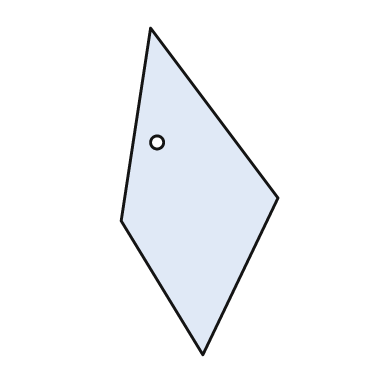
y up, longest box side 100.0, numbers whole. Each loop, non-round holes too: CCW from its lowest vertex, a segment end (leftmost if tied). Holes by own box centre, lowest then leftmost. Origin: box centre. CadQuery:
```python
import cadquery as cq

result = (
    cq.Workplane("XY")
    .moveTo(1.0, -50.0)
    .lineTo(24.0, -2.0)
    .lineTo(-15.0, 50.0)
    .lineTo(-24.0, -9.0)
    .close()
    .moveTo(-13.0, 15.0)
    .circle(2.0)
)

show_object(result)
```